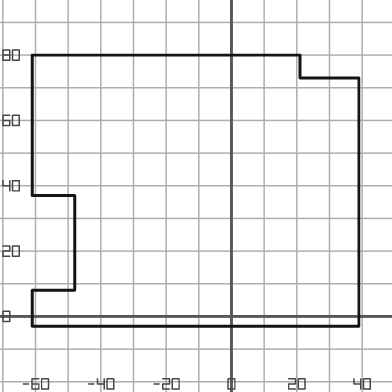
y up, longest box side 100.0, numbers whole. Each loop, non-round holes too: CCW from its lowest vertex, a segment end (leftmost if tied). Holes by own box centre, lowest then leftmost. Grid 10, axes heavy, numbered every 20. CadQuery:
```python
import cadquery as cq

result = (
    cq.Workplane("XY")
    .moveTo(-61.0, -3.0)
    .lineTo(39.0, -3.0)
    .lineTo(39.0, 73.0)
    .lineTo(21.0, 73.0)
    .lineTo(21.0, 80.0)
    .lineTo(-61.0, 80.0)
    .lineTo(-61.0, 37.0)
    .lineTo(-48.0, 37.0)
    .lineTo(-48.0, 8.0)
    .lineTo(-61.0, 8.0)
    .close()
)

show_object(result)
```